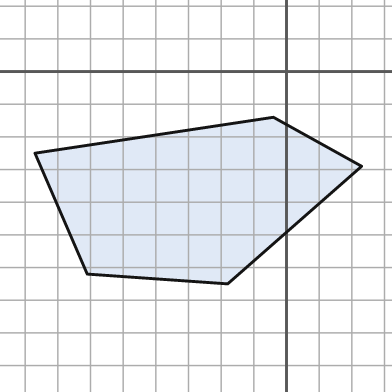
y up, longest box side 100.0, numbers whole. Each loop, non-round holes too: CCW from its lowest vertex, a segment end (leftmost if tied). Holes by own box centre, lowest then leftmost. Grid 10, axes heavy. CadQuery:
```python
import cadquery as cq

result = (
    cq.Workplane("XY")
    .moveTo(-18.0, -65.0)
    .lineTo(23.0, -29.0)
    .lineTo(-4.0, -14.0)
    .lineTo(-77.0, -25.0)
    .lineTo(-61.0, -62.0)
    .close()
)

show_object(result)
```